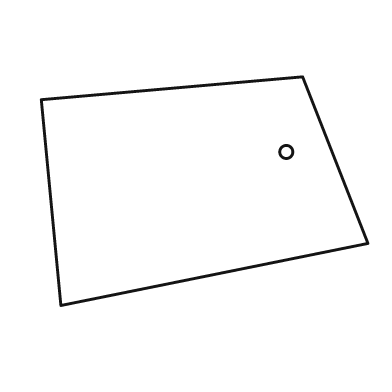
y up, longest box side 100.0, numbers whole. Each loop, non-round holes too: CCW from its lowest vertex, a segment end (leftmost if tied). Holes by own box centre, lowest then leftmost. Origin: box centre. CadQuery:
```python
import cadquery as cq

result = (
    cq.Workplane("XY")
    .moveTo(-44.0, -35.0)
    .lineTo(50.0, -16.0)
    .lineTo(30.0, 35.0)
    .lineTo(-50.0, 28.0)
    .close()
    .moveTo(25.0, 12.0)
    .circle(2.0)
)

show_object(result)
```